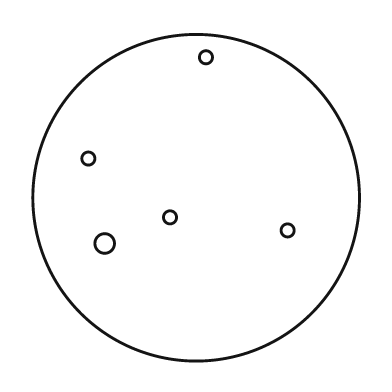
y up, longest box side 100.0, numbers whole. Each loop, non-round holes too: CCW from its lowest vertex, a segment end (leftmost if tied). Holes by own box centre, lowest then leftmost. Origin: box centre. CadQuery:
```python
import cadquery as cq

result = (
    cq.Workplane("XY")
    .moveTo(0.0, 0.0)
    .circle(50.0)
    .moveTo(-28.0, -14.0)
    .circle(3.0)
    .moveTo(28.0, -10.0)
    .circle(2.0)
    .moveTo(-8.0, -6.0)
    .circle(2.0)
    .moveTo(-33.0, 12.0)
    .circle(2.0)
    .moveTo(3.0, 43.0)
    .circle(2.0)
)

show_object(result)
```